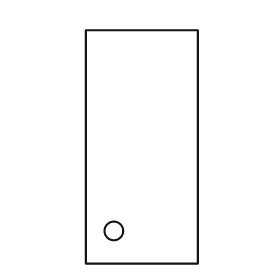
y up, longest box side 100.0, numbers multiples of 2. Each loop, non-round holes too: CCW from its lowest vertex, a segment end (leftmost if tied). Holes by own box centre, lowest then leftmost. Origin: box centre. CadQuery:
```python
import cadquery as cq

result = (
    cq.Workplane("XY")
    .moveTo(-24.0, -50.0)
    .lineTo(24.0, -50.0)
    .lineTo(24.0, 50.0)
    .lineTo(-24.0, 50.0)
    .close()
    .moveTo(-12.0, -36.0)
    .circle(4.0)
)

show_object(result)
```